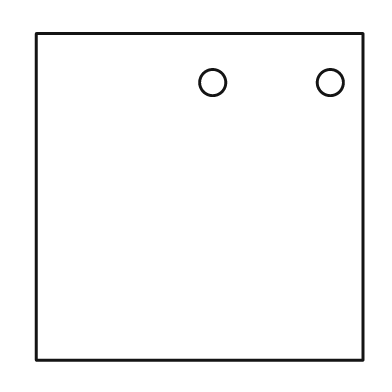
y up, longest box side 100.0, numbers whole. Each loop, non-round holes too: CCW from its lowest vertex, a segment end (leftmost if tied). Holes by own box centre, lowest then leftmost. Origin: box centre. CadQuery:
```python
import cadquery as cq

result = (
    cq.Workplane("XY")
    .moveTo(-50.0, -50.0)
    .lineTo(50.0, -50.0)
    .lineTo(50.0, 50.0)
    .lineTo(-50.0, 50.0)
    .close()
    .moveTo(4.0, 35.0)
    .circle(4.0)
    .moveTo(40.0, 35.0)
    .circle(4.0)
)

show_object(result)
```